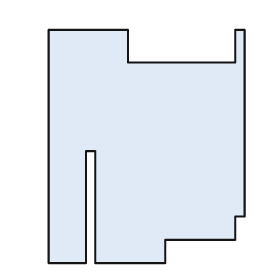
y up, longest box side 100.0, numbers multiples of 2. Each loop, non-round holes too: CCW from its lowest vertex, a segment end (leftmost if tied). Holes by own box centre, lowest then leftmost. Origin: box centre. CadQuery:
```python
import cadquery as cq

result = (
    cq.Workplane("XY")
    .moveTo(-42.0, -50.0)
    .lineTo(-26.0, -50.0)
    .lineTo(-26.0, -2.0)
    .lineTo(-22.0, -2.0)
    .lineTo(-22.0, -50.0)
    .lineTo(8.0, -50.0)
    .lineTo(8.0, -40.0)
    .lineTo(38.0, -40.0)
    .lineTo(38.0, -30.0)
    .lineTo(42.0, -30.0)
    .lineTo(42.0, 50.0)
    .lineTo(38.0, 50.0)
    .lineTo(38.0, 36.0)
    .lineTo(-8.0, 36.0)
    .lineTo(-8.0, 50.0)
    .lineTo(-42.0, 50.0)
    .close()
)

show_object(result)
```